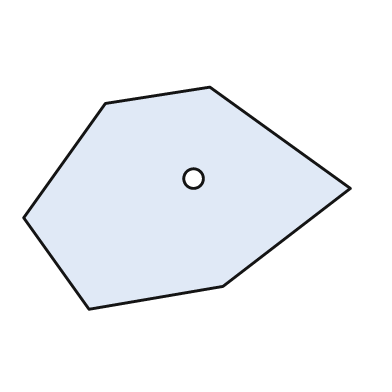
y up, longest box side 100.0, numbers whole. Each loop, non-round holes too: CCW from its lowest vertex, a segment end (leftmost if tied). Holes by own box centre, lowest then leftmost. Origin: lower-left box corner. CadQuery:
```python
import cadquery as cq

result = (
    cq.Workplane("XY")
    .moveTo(20.0, 0.0)
    .lineTo(61.0, 7.0)
    .lineTo(100.0, 37.0)
    .lineTo(57.0, 68.0)
    .lineTo(25.0, 63.0)
    .lineTo(0.0, 28.0)
    .close()
    .moveTo(52.0, 40.0)
    .circle(3.0)
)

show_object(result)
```